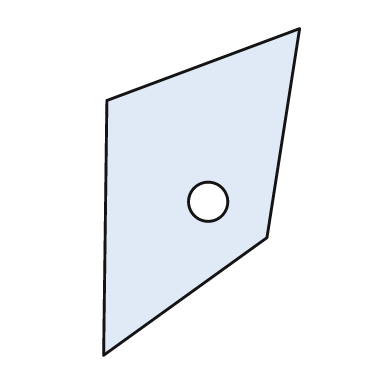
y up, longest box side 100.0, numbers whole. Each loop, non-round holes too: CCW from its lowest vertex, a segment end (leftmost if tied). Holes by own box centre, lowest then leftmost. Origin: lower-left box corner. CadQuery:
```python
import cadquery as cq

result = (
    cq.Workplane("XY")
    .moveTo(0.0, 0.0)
    .lineTo(50.0, 36.0)
    .lineTo(60.0, 100.0)
    .lineTo(1.0, 78.0)
    .close()
    .moveTo(32.0, 47.0)
    .circle(6.0)
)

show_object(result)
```